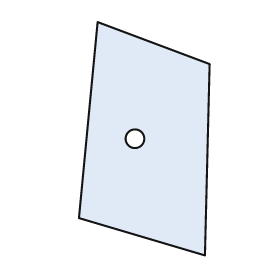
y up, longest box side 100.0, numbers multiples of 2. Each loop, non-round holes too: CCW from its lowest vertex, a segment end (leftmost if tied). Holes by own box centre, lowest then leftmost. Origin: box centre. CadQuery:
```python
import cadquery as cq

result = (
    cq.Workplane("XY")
    .moveTo(26.0, -50.0)
    .lineTo(28.0, 32.0)
    .lineTo(-20.0, 50.0)
    .lineTo(-28.0, -34.0)
    .close()
    .moveTo(-4.0, 0.0)
    .circle(4.0)
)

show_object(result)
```